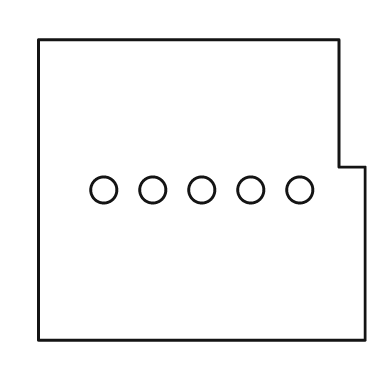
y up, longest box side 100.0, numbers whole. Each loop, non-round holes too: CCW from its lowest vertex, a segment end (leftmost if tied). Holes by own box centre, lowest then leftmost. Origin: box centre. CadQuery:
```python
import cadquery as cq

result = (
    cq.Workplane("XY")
    .moveTo(-50.0, -46.0)
    .lineTo(50.0, -46.0)
    .lineTo(50.0, 7.0)
    .lineTo(42.0, 7.0)
    .lineTo(42.0, 46.0)
    .lineTo(-50.0, 46.0)
    .close()
    .moveTo(-30.0, 0.0)
    .circle(4.0)
    .moveTo(-15.0, 0.0)
    .circle(4.0)
    .moveTo(0.0, 0.0)
    .circle(4.0)
    .moveTo(15.0, 0.0)
    .circle(4.0)
    .moveTo(30.0, 0.0)
    .circle(4.0)
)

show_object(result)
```